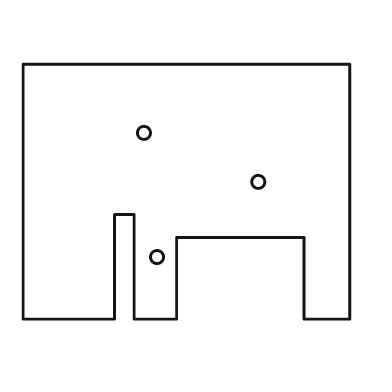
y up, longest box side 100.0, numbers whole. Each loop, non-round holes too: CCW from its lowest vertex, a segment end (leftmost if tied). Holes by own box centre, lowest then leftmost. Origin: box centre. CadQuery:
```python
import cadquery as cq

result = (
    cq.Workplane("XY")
    .moveTo(-50.0, -39.0)
    .lineTo(-22.0, -39.0)
    .lineTo(-22.0, -7.0)
    .lineTo(-16.0, -7.0)
    .lineTo(-16.0, -39.0)
    .lineTo(-3.0, -39.0)
    .lineTo(-3.0, -14.0)
    .lineTo(36.0, -14.0)
    .lineTo(36.0, -39.0)
    .lineTo(50.0, -39.0)
    .lineTo(50.0, 39.0)
    .lineTo(-50.0, 39.0)
    .close()
    .moveTo(-9.0, -20.0)
    .circle(2.0)
    .moveTo(22.0, 3.0)
    .circle(2.0)
    .moveTo(-13.0, 18.0)
    .circle(2.0)
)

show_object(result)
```